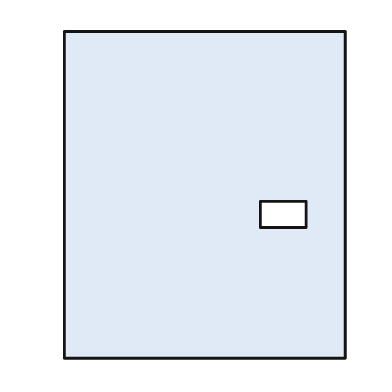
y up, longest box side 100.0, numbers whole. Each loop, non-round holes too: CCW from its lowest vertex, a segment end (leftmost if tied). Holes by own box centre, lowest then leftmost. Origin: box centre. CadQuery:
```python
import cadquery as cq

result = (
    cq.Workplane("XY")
    .moveTo(-43.0, -50.0)
    .lineTo(43.0, -50.0)
    .lineTo(43.0, 50.0)
    .lineTo(-43.0, 50.0)
    .close()
    .moveTo(17.0, -10.0)
    .lineTo(31.0, -10.0)
    .lineTo(31.0, -2.0)
    .lineTo(17.0, -2.0)
    .close()
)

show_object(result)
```